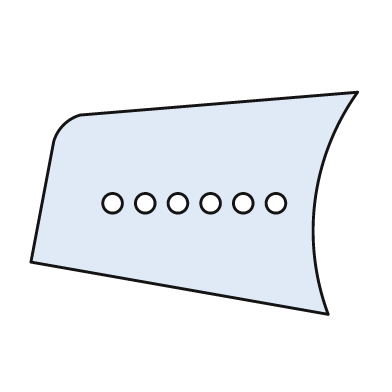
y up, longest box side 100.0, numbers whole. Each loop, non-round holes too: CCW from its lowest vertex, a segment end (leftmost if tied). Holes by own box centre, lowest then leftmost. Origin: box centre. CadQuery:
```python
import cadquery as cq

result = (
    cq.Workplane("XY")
    .moveTo(41.0, -34.0)
    .threePointArc((37.0, 1.0), (50.0, 34.0))
    .lineTo(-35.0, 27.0)
    .threePointArc((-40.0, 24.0), (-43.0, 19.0))
    .lineTo(-50.0, -18.0)
    .close()
    .moveTo(-25.0, 0.0)
    .circle(3.0)
    .moveTo(-15.0, 0.0)
    .circle(3.0)
    .moveTo(-5.0, 0.0)
    .circle(3.0)
    .moveTo(5.0, 0.0)
    .circle(3.0)
    .moveTo(15.0, 0.0)
    .circle(3.0)
    .moveTo(25.0, 0.0)
    .circle(3.0)
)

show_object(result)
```